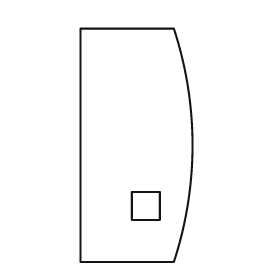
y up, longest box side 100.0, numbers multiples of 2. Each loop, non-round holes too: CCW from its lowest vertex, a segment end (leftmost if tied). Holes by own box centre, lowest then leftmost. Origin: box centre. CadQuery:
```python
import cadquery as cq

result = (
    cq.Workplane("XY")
    .moveTo(-24.0, -50.0)
    .lineTo(16.0, -50.0)
    .threePointArc((24.0, 0.0), (16.0, 50.0))
    .lineTo(-24.0, 50.0)
    .close()
    .moveTo(-2.0, -32.0)
    .lineTo(10.0, -32.0)
    .lineTo(10.0, -20.0)
    .lineTo(-2.0, -20.0)
    .close()
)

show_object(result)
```